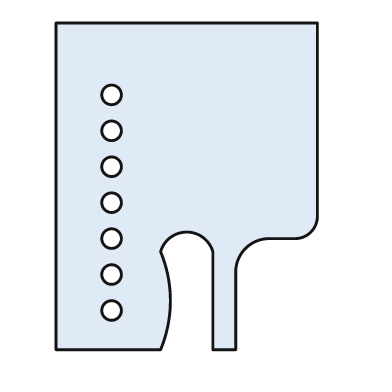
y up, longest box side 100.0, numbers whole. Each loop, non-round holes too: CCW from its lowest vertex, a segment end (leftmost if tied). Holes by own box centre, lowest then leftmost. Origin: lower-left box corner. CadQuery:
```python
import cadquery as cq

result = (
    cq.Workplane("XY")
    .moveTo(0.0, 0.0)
    .lineTo(32.0, 0.0)
    .threePointArc((35.0, 15.0), (32.0, 30.0))
    .threePointArc((40.0, 36.0), (48.0, 30.0))
    .lineTo(48.0, 0.0)
    .lineTo(55.0, 0.0)
    .lineTo(55.0, 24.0)
    .threePointArc((58.0, 31.0), (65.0, 34.0))
    .lineTo(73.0, 34.0)
    .threePointArc((78.0, 36.0), (80.0, 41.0))
    .lineTo(80.0, 100.0)
    .lineTo(0.0, 100.0)
    .close()
    .moveTo(17.0, 12.0)
    .circle(3.0)
    .moveTo(17.0, 23.0)
    .circle(3.0)
    .moveTo(17.0, 34.0)
    .circle(3.0)
    .moveTo(17.0, 45.0)
    .circle(3.0)
    .moveTo(17.0, 56.0)
    .circle(3.0)
    .moveTo(17.0, 67.0)
    .circle(3.0)
    .moveTo(17.0, 78.0)
    .circle(3.0)
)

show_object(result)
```